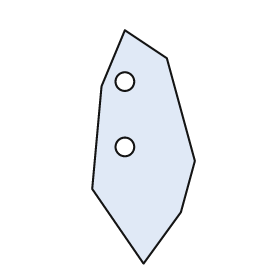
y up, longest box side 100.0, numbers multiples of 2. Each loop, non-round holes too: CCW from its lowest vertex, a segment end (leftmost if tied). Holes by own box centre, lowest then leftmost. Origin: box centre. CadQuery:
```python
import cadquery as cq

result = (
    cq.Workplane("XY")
    .moveTo(0.0, -50.0)
    .lineTo(16.0, -28.0)
    .lineTo(22.0, -6.0)
    .lineTo(10.0, 38.0)
    .lineTo(-8.0, 50.0)
    .lineTo(-18.0, 26.0)
    .lineTo(-22.0, -18.0)
    .close()
    .moveTo(-8.0, 0.0)
    .circle(4.0)
    .moveTo(-8.0, 28.0)
    .circle(4.0)
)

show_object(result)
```